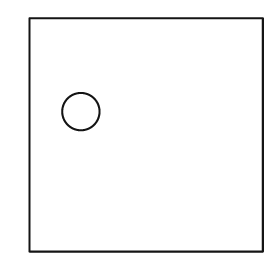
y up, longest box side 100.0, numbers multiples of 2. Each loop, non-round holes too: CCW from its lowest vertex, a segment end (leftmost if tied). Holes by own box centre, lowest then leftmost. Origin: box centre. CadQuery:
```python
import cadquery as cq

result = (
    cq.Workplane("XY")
    .moveTo(-50.0, -50.0)
    .lineTo(50.0, -50.0)
    .lineTo(50.0, 50.0)
    .lineTo(-50.0, 50.0)
    .close()
    .moveTo(-28.0, 10.0)
    .circle(8.0)
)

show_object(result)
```